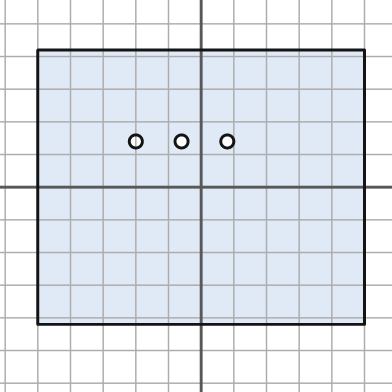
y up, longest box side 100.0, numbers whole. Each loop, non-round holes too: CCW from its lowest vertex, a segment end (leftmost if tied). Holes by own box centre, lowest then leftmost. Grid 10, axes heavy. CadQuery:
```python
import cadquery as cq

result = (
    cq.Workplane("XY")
    .moveTo(-50.0, -42.0)
    .lineTo(50.0, -42.0)
    .lineTo(50.0, 42.0)
    .lineTo(-50.0, 42.0)
    .close()
    .moveTo(-20.0, 14.0)
    .circle(2.0)
    .moveTo(-6.0, 14.0)
    .circle(2.0)
    .moveTo(8.0, 14.0)
    .circle(2.0)
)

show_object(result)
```